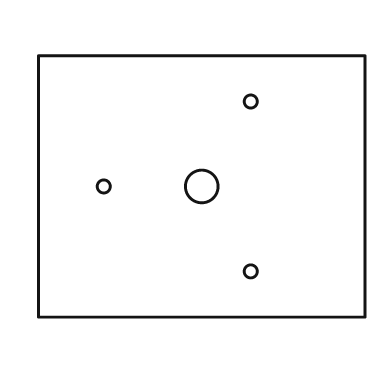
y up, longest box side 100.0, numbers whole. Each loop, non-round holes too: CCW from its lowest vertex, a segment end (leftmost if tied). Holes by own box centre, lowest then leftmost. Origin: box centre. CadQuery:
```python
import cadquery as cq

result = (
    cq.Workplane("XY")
    .moveTo(-50.0, -40.0)
    .lineTo(50.0, -40.0)
    .lineTo(50.0, 40.0)
    .lineTo(-50.0, 40.0)
    .close()
    .moveTo(15.0, -26.0)
    .circle(2.0)
    .moveTo(-30.0, 0.0)
    .circle(2.0)
    .moveTo(0.0, 0.0)
    .circle(5.0)
    .moveTo(15.0, 26.0)
    .circle(2.0)
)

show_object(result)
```